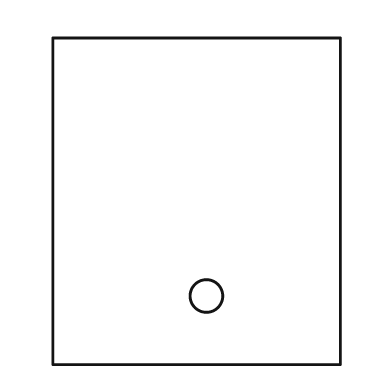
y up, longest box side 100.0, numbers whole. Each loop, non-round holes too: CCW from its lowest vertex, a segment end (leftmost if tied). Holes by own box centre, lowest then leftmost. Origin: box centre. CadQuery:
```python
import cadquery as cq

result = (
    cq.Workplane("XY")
    .moveTo(-44.0, -50.0)
    .lineTo(44.0, -50.0)
    .lineTo(44.0, 50.0)
    .lineTo(-44.0, 50.0)
    .close()
    .moveTo(3.0, -29.0)
    .circle(5.0)
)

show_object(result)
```